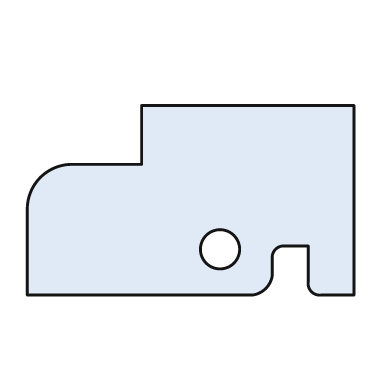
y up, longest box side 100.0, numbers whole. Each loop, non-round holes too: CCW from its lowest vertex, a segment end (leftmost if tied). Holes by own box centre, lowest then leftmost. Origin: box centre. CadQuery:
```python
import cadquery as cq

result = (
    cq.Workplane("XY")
    .moveTo(-50.0, -29.0)
    .lineTo(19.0, -29.0)
    .threePointArc((23.0, -27.0), (25.0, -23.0))
    .lineTo(25.0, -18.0)
    .threePointArc((26.0, -15.0), (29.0, -14.0))
    .lineTo(36.0, -14.0)
    .lineTo(36.0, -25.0)
    .threePointArc((37.0, -28.0), (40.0, -29.0))
    .lineTo(50.0, -29.0)
    .lineTo(50.0, 29.0)
    .lineTo(-15.0, 29.0)
    .lineTo(-15.0, 11.0)
    .lineTo(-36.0, 11.0)
    .threePointArc((-46.0, 7.0), (-50.0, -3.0))
    .close()
    .moveTo(9.0, -15.0)
    .circle(6.0)
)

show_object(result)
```